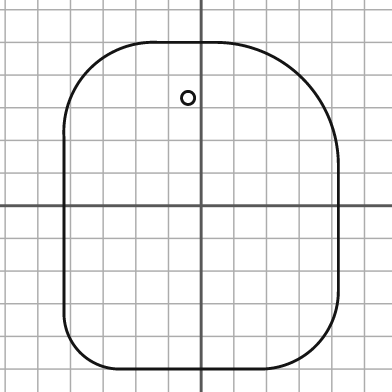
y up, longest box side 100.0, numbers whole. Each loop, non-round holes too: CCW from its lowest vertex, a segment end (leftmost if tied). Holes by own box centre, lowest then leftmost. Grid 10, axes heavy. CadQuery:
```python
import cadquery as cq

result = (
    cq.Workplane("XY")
    .moveTo(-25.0, -50.0)
    .lineTo(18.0, -50.0)
    .threePointArc((35.0, -43.0), (42.0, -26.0))
    .lineTo(42.0, 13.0)
    .threePointArc((31.0, 39.0), (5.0, 50.0))
    .lineTo(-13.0, 50.0)
    .threePointArc((-34.0, 42.0), (-42.0, 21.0))
    .lineTo(-42.0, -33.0)
    .threePointArc((-37.0, -45.0), (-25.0, -50.0))
    .close()
    .moveTo(-4.0, 33.0)
    .circle(2.0)
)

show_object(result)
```